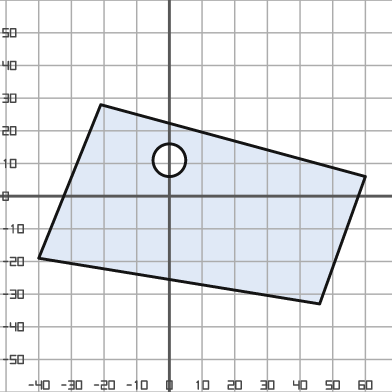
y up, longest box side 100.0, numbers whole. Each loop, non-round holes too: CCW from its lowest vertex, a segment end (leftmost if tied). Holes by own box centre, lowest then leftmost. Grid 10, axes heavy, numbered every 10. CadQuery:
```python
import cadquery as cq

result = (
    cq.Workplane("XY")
    .moveTo(46.0, -33.0)
    .lineTo(60.0, 6.0)
    .lineTo(-21.0, 28.0)
    .lineTo(-40.0, -19.0)
    .close()
    .moveTo(0.0, 11.0)
    .circle(5.0)
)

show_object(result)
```